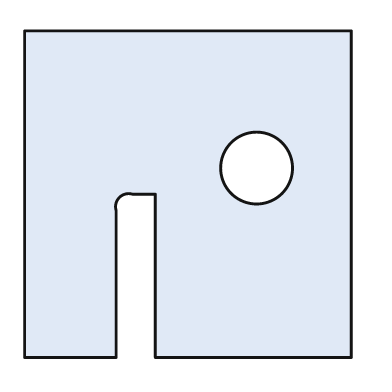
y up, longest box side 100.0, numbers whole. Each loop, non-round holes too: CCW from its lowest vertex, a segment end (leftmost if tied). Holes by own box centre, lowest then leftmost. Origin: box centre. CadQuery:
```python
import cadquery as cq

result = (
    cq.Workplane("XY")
    .moveTo(-50.0, -50.0)
    .lineTo(-22.0, -50.0)
    .lineTo(-22.0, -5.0)
    .threePointArc((-21.0, -1.0), (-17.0, 0.0))
    .lineTo(-10.0, 0.0)
    .lineTo(-10.0, -50.0)
    .lineTo(50.0, -50.0)
    .lineTo(50.0, 50.0)
    .lineTo(-50.0, 50.0)
    .close()
    .moveTo(21.0, 8.0)
    .circle(11.0)
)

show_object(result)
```